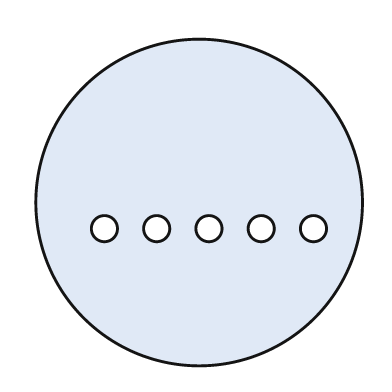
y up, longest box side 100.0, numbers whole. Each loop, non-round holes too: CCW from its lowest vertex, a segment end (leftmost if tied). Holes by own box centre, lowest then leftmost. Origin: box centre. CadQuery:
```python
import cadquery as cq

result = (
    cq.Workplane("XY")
    .moveTo(0.0, 0.0)
    .circle(50.0)
    .moveTo(-29.0, -8.0)
    .circle(4.0)
    .moveTo(-13.0, -8.0)
    .circle(4.0)
    .moveTo(3.0, -8.0)
    .circle(4.0)
    .moveTo(19.0, -8.0)
    .circle(4.0)
    .moveTo(35.0, -8.0)
    .circle(4.0)
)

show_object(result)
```